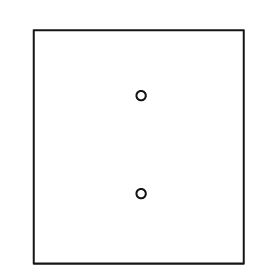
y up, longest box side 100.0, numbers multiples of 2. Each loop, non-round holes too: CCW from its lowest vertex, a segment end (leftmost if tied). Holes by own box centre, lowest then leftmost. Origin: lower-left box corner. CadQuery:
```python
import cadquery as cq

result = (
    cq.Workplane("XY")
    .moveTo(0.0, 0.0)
    .lineTo(90.0, 0.0)
    .lineTo(90.0, 100.0)
    .lineTo(0.0, 100.0)
    .close()
    .moveTo(46.0, 30.0)
    .circle(2.0)
    .moveTo(46.0, 72.0)
    .circle(2.0)
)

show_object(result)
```